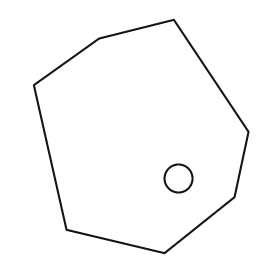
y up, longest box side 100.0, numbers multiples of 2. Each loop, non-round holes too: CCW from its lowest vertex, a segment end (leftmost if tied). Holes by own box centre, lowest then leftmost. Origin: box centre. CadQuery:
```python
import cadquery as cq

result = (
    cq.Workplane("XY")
    .moveTo(10.0, -50.0)
    .lineTo(40.0, -26.0)
    .lineTo(46.0, 2.0)
    .lineTo(14.0, 50.0)
    .lineTo(-18.0, 42.0)
    .lineTo(-46.0, 22.0)
    .lineTo(-32.0, -40.0)
    .close()
    .moveTo(16.0, -18.0)
    .circle(6.0)
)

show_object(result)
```